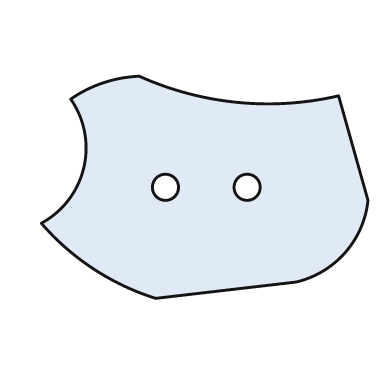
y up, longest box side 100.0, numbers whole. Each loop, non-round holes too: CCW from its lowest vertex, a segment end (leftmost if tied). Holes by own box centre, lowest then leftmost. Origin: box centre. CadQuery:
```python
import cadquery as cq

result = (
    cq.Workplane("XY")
    .moveTo(-15.0, -34.0)
    .lineTo(28.0, -29.0)
    .threePointArc((43.0, -20.0), (50.0, -4.0))
    .lineTo(41.0, 28.0)
    .threePointArc((10.0, 26.0), (-20.0, 34.0))
    .threePointArc((-31.0, 32.0), (-41.0, 27.0))
    .threePointArc((-37.0, 6.0), (-50.0, -11.0))
    .threePointArc((-34.0, -25.0), (-15.0, -34.0))
    .close()
    .moveTo(-12.0, 0.0)
    .circle(4.0)
    .moveTo(13.0, 0.0)
    .circle(4.0)
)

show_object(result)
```